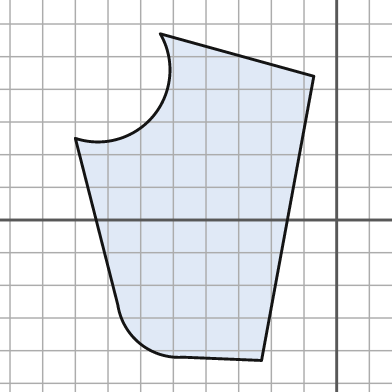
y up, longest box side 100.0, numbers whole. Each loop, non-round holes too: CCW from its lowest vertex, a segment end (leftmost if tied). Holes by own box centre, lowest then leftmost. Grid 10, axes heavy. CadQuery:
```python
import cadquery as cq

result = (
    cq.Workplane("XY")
    .moveTo(-23.0, -43.0)
    .lineTo(-7.0, 44.0)
    .lineTo(-54.0, 57.0)
    .threePointArc((-56.0, 32.0), (-80.0, 25.0))
    .lineTo(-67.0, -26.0)
    .threePointArc((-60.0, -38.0), (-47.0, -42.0))
    .close()
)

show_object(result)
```